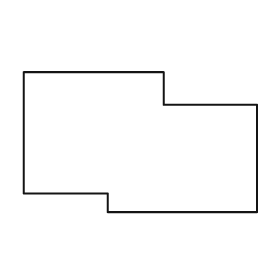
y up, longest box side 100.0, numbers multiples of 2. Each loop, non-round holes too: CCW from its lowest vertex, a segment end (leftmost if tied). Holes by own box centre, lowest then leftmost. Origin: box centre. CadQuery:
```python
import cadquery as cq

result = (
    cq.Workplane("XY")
    .moveTo(-14.0, -30.0)
    .lineTo(50.0, -30.0)
    .lineTo(50.0, 16.0)
    .lineTo(10.0, 16.0)
    .lineTo(10.0, 30.0)
    .lineTo(-50.0, 30.0)
    .lineTo(-50.0, -22.0)
    .lineTo(-14.0, -22.0)
    .close()
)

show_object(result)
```